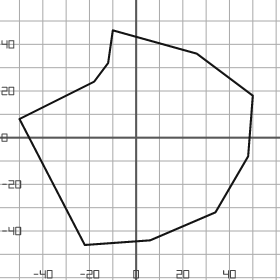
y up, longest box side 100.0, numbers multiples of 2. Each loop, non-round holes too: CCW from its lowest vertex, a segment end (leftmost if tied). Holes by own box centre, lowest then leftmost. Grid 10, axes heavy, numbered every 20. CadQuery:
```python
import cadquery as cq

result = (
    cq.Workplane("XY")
    .moveTo(-22.0, -46.0)
    .lineTo(6.0, -44.0)
    .lineTo(34.0, -32.0)
    .lineTo(48.0, -8.0)
    .lineTo(50.0, 18.0)
    .lineTo(26.0, 36.0)
    .lineTo(-10.0, 46.0)
    .lineTo(-12.0, 32.0)
    .lineTo(-18.0, 24.0)
    .lineTo(-50.0, 8.0)
    .close()
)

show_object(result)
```